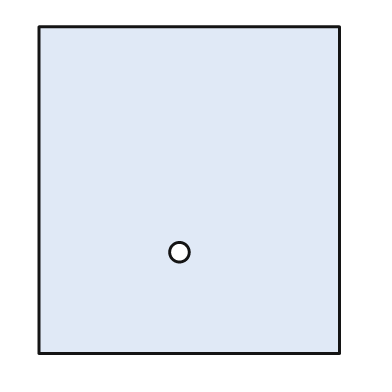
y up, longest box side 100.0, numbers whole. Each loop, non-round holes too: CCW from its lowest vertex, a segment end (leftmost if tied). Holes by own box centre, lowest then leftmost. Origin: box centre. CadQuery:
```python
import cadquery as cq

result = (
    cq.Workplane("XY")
    .moveTo(-46.0, -50.0)
    .lineTo(46.0, -50.0)
    .lineTo(46.0, 50.0)
    .lineTo(-46.0, 50.0)
    .close()
    .moveTo(-3.0, -19.0)
    .circle(3.0)
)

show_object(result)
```